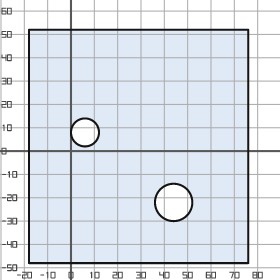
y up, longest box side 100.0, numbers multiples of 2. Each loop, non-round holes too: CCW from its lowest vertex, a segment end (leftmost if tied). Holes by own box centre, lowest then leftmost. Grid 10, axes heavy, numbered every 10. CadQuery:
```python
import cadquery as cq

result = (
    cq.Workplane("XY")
    .moveTo(-18.0, -48.0)
    .lineTo(76.0, -48.0)
    .lineTo(76.0, 52.0)
    .lineTo(-18.0, 52.0)
    .close()
    .moveTo(44.0, -22.0)
    .circle(8.0)
    .moveTo(6.0, 8.0)
    .circle(6.0)
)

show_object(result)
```